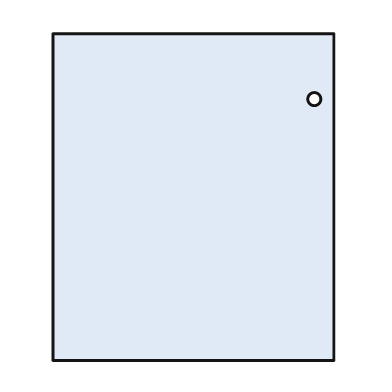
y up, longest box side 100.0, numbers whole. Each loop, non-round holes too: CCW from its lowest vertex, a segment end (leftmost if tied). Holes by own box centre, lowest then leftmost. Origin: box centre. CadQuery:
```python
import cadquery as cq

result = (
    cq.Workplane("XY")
    .moveTo(-43.0, -50.0)
    .lineTo(43.0, -50.0)
    .lineTo(43.0, 50.0)
    .lineTo(-43.0, 50.0)
    .close()
    .moveTo(37.0, 30.0)
    .circle(2.0)
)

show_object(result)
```